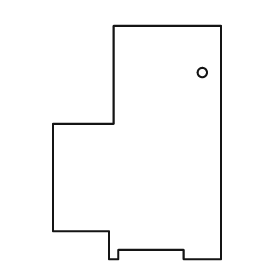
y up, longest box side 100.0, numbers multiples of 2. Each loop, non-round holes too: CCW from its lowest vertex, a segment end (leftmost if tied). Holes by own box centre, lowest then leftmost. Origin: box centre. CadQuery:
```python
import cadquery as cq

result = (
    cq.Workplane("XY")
    .moveTo(-12.0, -50.0)
    .lineTo(-8.0, -50.0)
    .lineTo(-8.0, -46.0)
    .lineTo(20.0, -46.0)
    .lineTo(20.0, -50.0)
    .lineTo(36.0, -50.0)
    .lineTo(36.0, 50.0)
    .lineTo(-10.0, 50.0)
    .lineTo(-10.0, 8.0)
    .lineTo(-36.0, 8.0)
    .lineTo(-36.0, -38.0)
    .lineTo(-12.0, -38.0)
    .close()
    .moveTo(28.0, 30.0)
    .circle(2.0)
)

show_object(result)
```